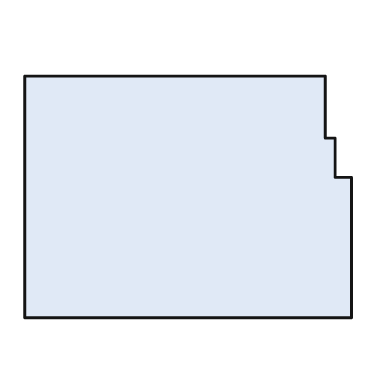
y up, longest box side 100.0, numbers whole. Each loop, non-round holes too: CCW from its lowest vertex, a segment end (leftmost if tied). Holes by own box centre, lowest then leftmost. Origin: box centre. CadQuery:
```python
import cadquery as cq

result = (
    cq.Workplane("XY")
    .moveTo(-50.0, -37.0)
    .lineTo(50.0, -37.0)
    .lineTo(50.0, 6.0)
    .lineTo(45.0, 6.0)
    .lineTo(45.0, 18.0)
    .lineTo(42.0, 18.0)
    .lineTo(42.0, 37.0)
    .lineTo(-50.0, 37.0)
    .close()
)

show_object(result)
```